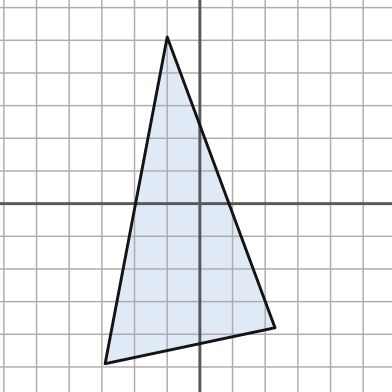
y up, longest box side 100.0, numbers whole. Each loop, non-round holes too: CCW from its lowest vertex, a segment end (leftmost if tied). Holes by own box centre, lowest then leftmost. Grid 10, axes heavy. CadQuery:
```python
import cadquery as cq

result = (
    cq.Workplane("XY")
    .moveTo(-29.0, -49.0)
    .lineTo(23.0, -38.0)
    .lineTo(-10.0, 51.0)
    .close()
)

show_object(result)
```